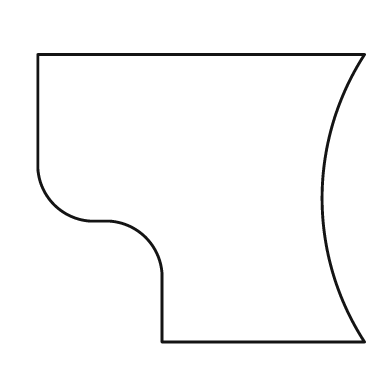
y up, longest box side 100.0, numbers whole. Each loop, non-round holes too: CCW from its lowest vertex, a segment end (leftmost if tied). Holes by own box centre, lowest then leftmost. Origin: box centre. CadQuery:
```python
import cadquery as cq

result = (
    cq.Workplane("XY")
    .moveTo(-12.0, -44.0)
    .lineTo(50.0, -44.0)
    .threePointArc((37.0, 0.0), (50.0, 44.0))
    .lineTo(-50.0, 44.0)
    .lineTo(-50.0, 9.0)
    .threePointArc((-45.0, -2.0), (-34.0, -7.0))
    .lineTo(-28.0, -7.0)
    .threePointArc((-17.0, -12.0), (-12.0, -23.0))
    .close()
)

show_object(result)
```